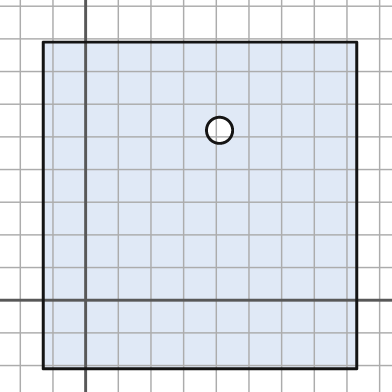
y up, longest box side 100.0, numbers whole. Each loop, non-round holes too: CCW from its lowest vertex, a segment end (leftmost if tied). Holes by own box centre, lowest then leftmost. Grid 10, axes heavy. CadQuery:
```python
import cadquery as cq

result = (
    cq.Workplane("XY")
    .moveTo(-13.0, -21.0)
    .lineTo(83.0, -21.0)
    .lineTo(83.0, 79.0)
    .lineTo(-13.0, 79.0)
    .close()
    .moveTo(41.0, 52.0)
    .circle(4.0)
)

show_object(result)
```